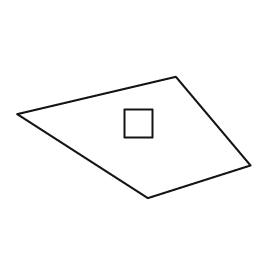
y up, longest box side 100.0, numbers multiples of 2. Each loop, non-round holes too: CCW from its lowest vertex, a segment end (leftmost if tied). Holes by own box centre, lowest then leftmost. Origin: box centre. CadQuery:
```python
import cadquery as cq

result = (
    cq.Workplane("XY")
    .moveTo(6.0, -26.0)
    .lineTo(50.0, -12.0)
    .lineTo(18.0, 26.0)
    .lineTo(-50.0, 10.0)
    .close()
    .moveTo(-4.0, 0.0)
    .lineTo(8.0, 0.0)
    .lineTo(8.0, 12.0)
    .lineTo(-4.0, 12.0)
    .close()
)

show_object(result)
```